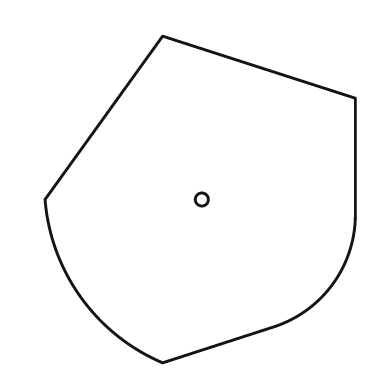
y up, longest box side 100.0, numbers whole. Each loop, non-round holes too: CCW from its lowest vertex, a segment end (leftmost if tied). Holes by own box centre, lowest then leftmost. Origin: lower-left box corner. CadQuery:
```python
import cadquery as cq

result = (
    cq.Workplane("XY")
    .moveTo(36.0, 0.0)
    .lineTo(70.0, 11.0)
    .threePointArc((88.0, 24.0), (95.0, 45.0))
    .lineTo(95.0, 81.0)
    .lineTo(36.0, 100.0)
    .lineTo(0.0, 50.0)
    .threePointArc((11.0, 20.0), (36.0, 0.0))
    .close()
    .moveTo(48.0, 50.0)
    .circle(2.0)
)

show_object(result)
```